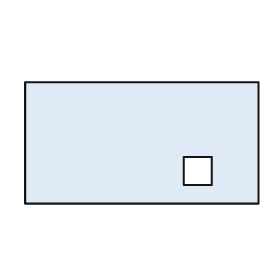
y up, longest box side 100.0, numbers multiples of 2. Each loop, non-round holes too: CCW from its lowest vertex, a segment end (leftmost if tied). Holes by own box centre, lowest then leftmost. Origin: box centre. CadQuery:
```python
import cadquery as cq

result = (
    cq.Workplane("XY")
    .moveTo(-50.0, -26.0)
    .lineTo(50.0, -26.0)
    .lineTo(50.0, 26.0)
    .lineTo(-50.0, 26.0)
    .close()
    .moveTo(18.0, -18.0)
    .lineTo(30.0, -18.0)
    .lineTo(30.0, -6.0)
    .lineTo(18.0, -6.0)
    .close()
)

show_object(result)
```